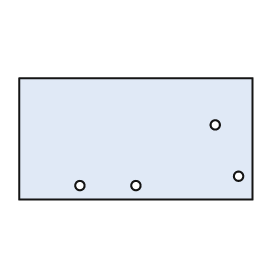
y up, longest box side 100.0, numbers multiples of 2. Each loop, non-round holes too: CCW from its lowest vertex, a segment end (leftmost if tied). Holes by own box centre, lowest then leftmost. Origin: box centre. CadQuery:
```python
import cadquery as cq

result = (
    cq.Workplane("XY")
    .moveTo(-50.0, -26.0)
    .lineTo(50.0, -26.0)
    .lineTo(50.0, 26.0)
    .lineTo(-50.0, 26.0)
    .close()
    .moveTo(-24.0, -20.0)
    .circle(2.0)
    .moveTo(0.0, -20.0)
    .circle(2.0)
    .moveTo(44.0, -16.0)
    .circle(2.0)
    .moveTo(34.0, 6.0)
    .circle(2.0)
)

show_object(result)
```